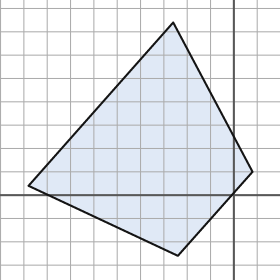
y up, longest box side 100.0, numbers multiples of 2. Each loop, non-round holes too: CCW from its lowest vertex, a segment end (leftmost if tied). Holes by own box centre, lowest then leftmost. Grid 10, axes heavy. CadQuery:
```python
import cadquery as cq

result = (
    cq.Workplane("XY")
    .moveTo(-24.0, -26.0)
    .lineTo(8.0, 10.0)
    .lineTo(-26.0, 74.0)
    .lineTo(-88.0, 4.0)
    .close()
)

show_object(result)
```